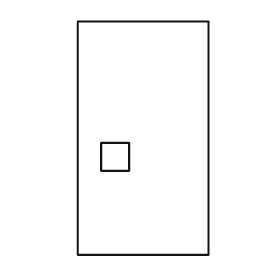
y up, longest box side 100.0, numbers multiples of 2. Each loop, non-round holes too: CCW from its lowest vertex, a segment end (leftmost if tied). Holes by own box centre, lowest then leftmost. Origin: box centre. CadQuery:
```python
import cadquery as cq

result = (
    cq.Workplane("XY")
    .moveTo(-28.0, -50.0)
    .lineTo(28.0, -50.0)
    .lineTo(28.0, 50.0)
    .lineTo(-28.0, 50.0)
    .close()
    .moveTo(-18.0, -14.0)
    .lineTo(-6.0, -14.0)
    .lineTo(-6.0, -2.0)
    .lineTo(-18.0, -2.0)
    .close()
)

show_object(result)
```